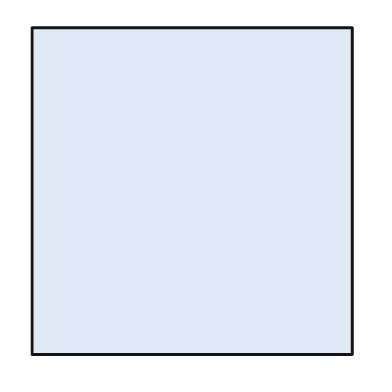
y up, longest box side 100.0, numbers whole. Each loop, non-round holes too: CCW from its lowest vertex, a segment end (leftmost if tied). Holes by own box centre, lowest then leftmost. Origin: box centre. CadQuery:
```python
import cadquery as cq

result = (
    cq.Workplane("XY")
    .moveTo(-49.0, -50.0)
    .lineTo(49.0, -50.0)
    .lineTo(49.0, 50.0)
    .lineTo(-49.0, 50.0)
    .close()
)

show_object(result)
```